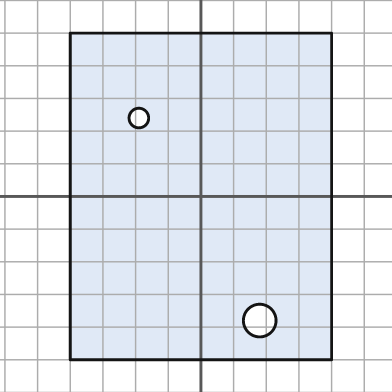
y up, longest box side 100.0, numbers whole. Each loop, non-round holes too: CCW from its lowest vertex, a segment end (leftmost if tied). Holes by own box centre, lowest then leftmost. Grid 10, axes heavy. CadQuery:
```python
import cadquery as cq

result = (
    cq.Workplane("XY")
    .moveTo(-40.0, -50.0)
    .lineTo(40.0, -50.0)
    .lineTo(40.0, 50.0)
    .lineTo(-40.0, 50.0)
    .close()
    .moveTo(18.0, -38.0)
    .circle(5.0)
    .moveTo(-19.0, 24.0)
    .circle(3.0)
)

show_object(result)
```